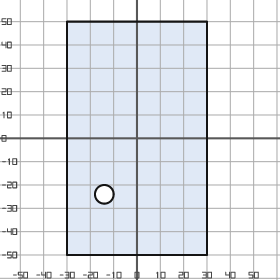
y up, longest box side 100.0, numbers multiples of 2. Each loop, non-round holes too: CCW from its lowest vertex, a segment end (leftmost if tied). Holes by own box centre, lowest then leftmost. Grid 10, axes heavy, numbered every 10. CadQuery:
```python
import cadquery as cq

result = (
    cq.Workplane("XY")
    .moveTo(-30.0, -50.0)
    .lineTo(30.0, -50.0)
    .lineTo(30.0, 50.0)
    .lineTo(-30.0, 50.0)
    .close()
    .moveTo(-14.0, -24.0)
    .circle(4.0)
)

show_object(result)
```